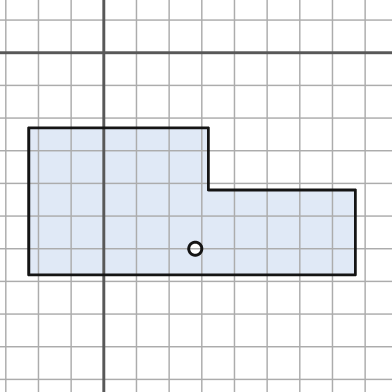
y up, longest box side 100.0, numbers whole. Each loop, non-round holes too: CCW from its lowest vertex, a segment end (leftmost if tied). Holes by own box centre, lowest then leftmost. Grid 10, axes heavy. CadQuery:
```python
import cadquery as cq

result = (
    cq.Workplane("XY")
    .moveTo(-23.0, -68.0)
    .lineTo(77.0, -68.0)
    .lineTo(77.0, -42.0)
    .lineTo(32.0, -42.0)
    .lineTo(32.0, -23.0)
    .lineTo(-23.0, -23.0)
    .close()
    .moveTo(28.0, -60.0)
    .circle(2.0)
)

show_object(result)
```